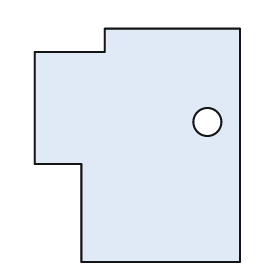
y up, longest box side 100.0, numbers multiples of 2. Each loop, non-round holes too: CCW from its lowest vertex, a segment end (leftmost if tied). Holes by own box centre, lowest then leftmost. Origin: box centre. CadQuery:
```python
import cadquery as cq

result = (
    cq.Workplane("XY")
    .moveTo(-24.0, -50.0)
    .lineTo(44.0, -50.0)
    .lineTo(44.0, 50.0)
    .lineTo(-14.0, 50.0)
    .lineTo(-14.0, 40.0)
    .lineTo(-44.0, 40.0)
    .lineTo(-44.0, -8.0)
    .lineTo(-24.0, -8.0)
    .close()
    .moveTo(30.0, 10.0)
    .circle(6.0)
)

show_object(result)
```